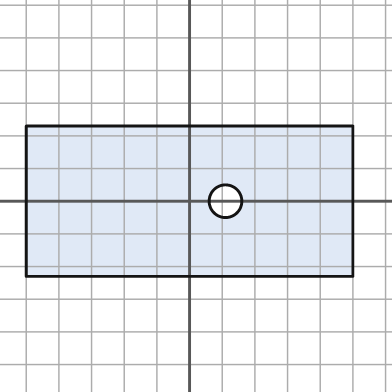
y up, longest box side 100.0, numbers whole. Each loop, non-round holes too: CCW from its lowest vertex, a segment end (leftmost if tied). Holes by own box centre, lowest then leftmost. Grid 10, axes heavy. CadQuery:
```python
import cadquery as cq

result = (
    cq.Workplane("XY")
    .moveTo(-50.0, -23.0)
    .lineTo(50.0, -23.0)
    .lineTo(50.0, 23.0)
    .lineTo(-50.0, 23.0)
    .close()
    .moveTo(11.0, 0.0)
    .circle(5.0)
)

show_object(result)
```